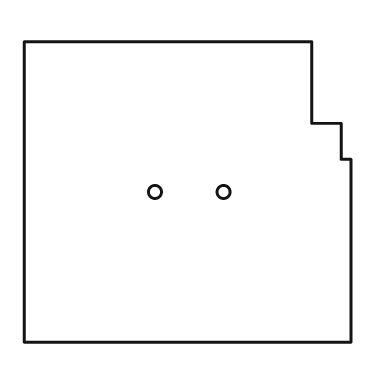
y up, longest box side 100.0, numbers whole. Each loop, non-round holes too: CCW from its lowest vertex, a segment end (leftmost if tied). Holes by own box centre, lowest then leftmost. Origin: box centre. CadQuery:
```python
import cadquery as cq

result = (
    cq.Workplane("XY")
    .moveTo(-50.0, -46.0)
    .lineTo(50.0, -46.0)
    .lineTo(50.0, 10.0)
    .lineTo(47.0, 10.0)
    .lineTo(47.0, 21.0)
    .lineTo(38.0, 21.0)
    .lineTo(38.0, 46.0)
    .lineTo(-50.0, 46.0)
    .close()
    .moveTo(-10.0, 0.0)
    .circle(2.0)
    .moveTo(11.0, 0.0)
    .circle(2.0)
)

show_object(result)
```